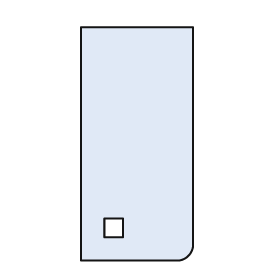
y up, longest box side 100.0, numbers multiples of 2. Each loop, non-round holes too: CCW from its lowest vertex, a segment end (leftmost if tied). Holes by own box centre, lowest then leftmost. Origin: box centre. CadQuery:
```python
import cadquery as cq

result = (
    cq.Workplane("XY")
    .moveTo(-24.0, -50.0)
    .lineTo(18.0, -50.0)
    .threePointArc((22.0, -48.0), (24.0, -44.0))
    .lineTo(24.0, 50.0)
    .lineTo(-24.0, 50.0)
    .close()
    .moveTo(-14.0, -40.0)
    .lineTo(-6.0, -40.0)
    .lineTo(-6.0, -32.0)
    .lineTo(-14.0, -32.0)
    .close()
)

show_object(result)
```